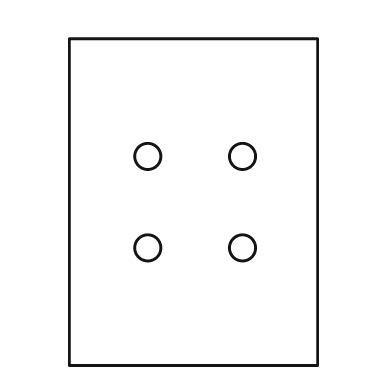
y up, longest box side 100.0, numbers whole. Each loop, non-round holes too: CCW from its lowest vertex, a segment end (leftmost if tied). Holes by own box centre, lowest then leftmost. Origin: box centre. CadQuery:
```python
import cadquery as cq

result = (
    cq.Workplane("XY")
    .moveTo(-38.0, -50.0)
    .lineTo(38.0, -50.0)
    .lineTo(38.0, 50.0)
    .lineTo(-38.0, 50.0)
    .close()
    .moveTo(-14.0, -14.0)
    .circle(4.0)
    .moveTo(15.0, -14.0)
    .circle(4.0)
    .moveTo(-14.0, 14.0)
    .circle(4.0)
    .moveTo(15.0, 14.0)
    .circle(4.0)
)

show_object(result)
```